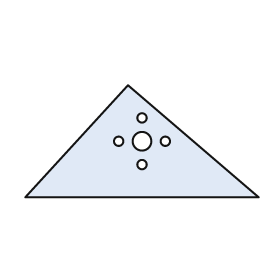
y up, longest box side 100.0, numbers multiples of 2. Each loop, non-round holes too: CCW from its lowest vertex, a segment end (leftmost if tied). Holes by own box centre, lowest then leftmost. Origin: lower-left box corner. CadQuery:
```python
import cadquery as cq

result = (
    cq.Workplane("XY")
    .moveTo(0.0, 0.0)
    .lineTo(100.0, 0.0)
    .lineTo(44.0, 48.0)
    .close()
    .moveTo(50.0, 14.0)
    .circle(2.0)
    .moveTo(40.0, 24.0)
    .circle(2.0)
    .moveTo(50.0, 24.0)
    .circle(4.0)
    .moveTo(60.0, 24.0)
    .circle(2.0)
    .moveTo(50.0, 34.0)
    .circle(2.0)
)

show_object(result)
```